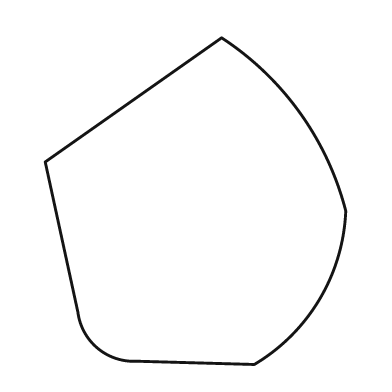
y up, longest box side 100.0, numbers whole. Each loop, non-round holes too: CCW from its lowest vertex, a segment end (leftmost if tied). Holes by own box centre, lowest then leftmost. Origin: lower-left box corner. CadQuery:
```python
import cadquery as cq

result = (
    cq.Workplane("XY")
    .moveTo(64.0, 0.0)
    .threePointArc((84.0, 20.0), (92.0, 47.0))
    .threePointArc((78.0, 77.0), (54.0, 100.0))
    .lineTo(0.0, 62.0)
    .lineTo(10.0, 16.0)
    .threePointArc((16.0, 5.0), (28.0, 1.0))
    .close()
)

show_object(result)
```